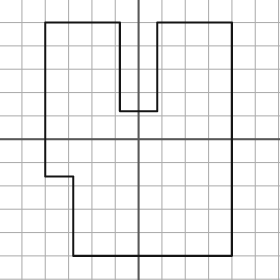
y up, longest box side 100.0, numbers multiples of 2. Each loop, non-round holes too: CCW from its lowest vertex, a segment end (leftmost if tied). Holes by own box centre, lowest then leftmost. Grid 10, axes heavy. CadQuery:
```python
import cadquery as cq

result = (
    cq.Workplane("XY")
    .moveTo(-28.0, -50.0)
    .lineTo(40.0, -50.0)
    .lineTo(40.0, 50.0)
    .lineTo(8.0, 50.0)
    .lineTo(8.0, 12.0)
    .lineTo(-8.0, 12.0)
    .lineTo(-8.0, 50.0)
    .lineTo(-40.0, 50.0)
    .lineTo(-40.0, -16.0)
    .lineTo(-28.0, -16.0)
    .close()
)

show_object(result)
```